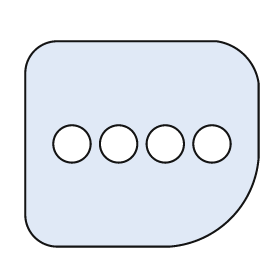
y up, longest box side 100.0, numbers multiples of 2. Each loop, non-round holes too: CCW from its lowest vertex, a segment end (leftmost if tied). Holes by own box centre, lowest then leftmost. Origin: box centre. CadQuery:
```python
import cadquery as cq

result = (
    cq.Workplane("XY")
    .moveTo(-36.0, -44.0)
    .lineTo(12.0, -44.0)
    .threePointArc((38.0, -32.0), (50.0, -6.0))
    .lineTo(50.0, 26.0)
    .threePointArc((44.0, 38.0), (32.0, 44.0))
    .lineTo(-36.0, 44.0)
    .threePointArc((-46.0, 40.0), (-50.0, 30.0))
    .lineTo(-50.0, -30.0)
    .threePointArc((-46.0, -40.0), (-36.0, -44.0))
    .close()
    .moveTo(-30.0, 0.0)
    .circle(8.0)
    .moveTo(-10.0, 0.0)
    .circle(8.0)
    .moveTo(10.0, 0.0)
    .circle(8.0)
    .moveTo(30.0, 0.0)
    .circle(8.0)
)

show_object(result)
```